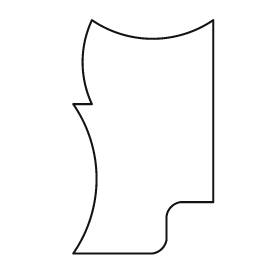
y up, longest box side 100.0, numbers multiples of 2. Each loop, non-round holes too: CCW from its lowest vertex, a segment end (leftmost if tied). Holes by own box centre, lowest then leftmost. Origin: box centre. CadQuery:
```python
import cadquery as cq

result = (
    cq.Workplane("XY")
    .moveTo(-30.0, -50.0)
    .lineTo(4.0, -50.0)
    .threePointArc((8.0, -48.0), (10.0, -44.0))
    .lineTo(10.0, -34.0)
    .threePointArc((12.0, -30.0), (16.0, -28.0))
    .lineTo(30.0, -28.0)
    .lineTo(30.0, 50.0)
    .threePointArc((4.0, 42.0), (-22.0, 50.0))
    .threePointArc((-26.0, 32.0), (-22.0, 14.0))
    .lineTo(-30.0, 14.0)
    .threePointArc((-20.0, -18.0), (-30.0, -50.0))
    .close()
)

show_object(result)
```